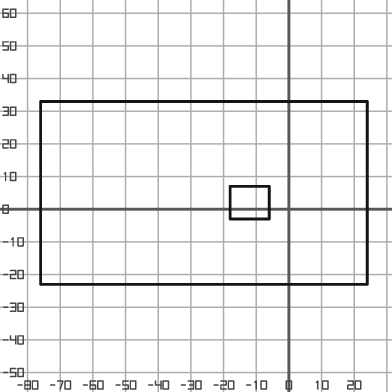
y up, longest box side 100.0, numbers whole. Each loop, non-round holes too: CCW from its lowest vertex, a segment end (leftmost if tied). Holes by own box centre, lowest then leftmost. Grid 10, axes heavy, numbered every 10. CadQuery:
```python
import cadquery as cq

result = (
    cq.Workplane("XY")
    .moveTo(-76.0, -23.0)
    .lineTo(24.0, -23.0)
    .lineTo(24.0, 33.0)
    .lineTo(-76.0, 33.0)
    .close()
    .moveTo(-18.0, -3.0)
    .lineTo(-6.0, -3.0)
    .lineTo(-6.0, 7.0)
    .lineTo(-18.0, 7.0)
    .close()
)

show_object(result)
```